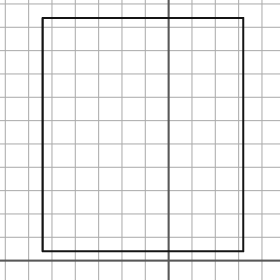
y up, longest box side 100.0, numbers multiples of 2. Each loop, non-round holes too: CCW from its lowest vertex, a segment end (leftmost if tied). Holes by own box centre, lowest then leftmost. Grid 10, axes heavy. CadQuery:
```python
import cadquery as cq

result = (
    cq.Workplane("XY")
    .moveTo(-54.0, 4.0)
    .lineTo(32.0, 4.0)
    .lineTo(32.0, 104.0)
    .lineTo(-54.0, 104.0)
    .close()
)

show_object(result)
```